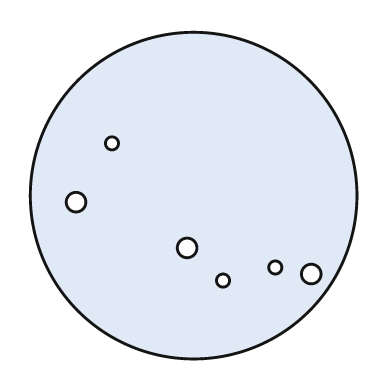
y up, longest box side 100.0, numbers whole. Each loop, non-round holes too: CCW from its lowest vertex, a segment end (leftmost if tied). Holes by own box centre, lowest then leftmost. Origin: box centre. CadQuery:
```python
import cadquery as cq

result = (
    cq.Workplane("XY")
    .moveTo(0.0, 0.0)
    .circle(50.0)
    .moveTo(9.0, -26.0)
    .circle(2.0)
    .moveTo(36.0, -24.0)
    .circle(3.0)
    .moveTo(25.0, -22.0)
    .circle(2.0)
    .moveTo(-2.0, -16.0)
    .circle(3.0)
    .moveTo(-36.0, -2.0)
    .circle(3.0)
    .moveTo(-25.0, 16.0)
    .circle(2.0)
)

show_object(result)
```